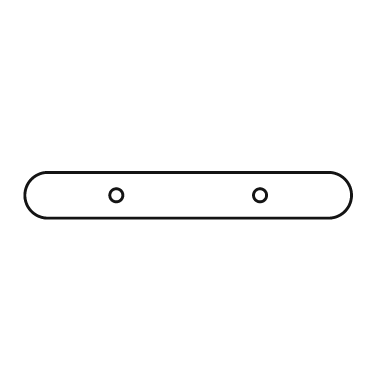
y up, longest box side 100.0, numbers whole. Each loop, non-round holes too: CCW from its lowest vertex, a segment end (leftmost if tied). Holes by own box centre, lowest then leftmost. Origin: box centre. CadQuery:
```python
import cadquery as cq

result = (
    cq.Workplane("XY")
    .moveTo(-43.0, -7.0)
    .lineTo(43.0, -7.0)
    .threePointArc((50.0, 0.0), (43.0, 7.0))
    .lineTo(-43.0, 7.0)
    .threePointArc((-50.0, 0.0), (-43.0, -7.0))
    .close()
    .moveTo(-22.0, 0.0)
    .circle(2.0)
    .moveTo(22.0, 0.0)
    .circle(2.0)
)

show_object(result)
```